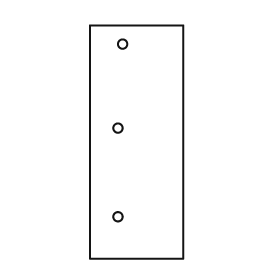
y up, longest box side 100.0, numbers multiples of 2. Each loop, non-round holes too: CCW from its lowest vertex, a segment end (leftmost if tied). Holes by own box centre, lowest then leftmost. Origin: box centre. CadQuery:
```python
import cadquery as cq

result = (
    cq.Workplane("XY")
    .moveTo(-20.0, -50.0)
    .lineTo(20.0, -50.0)
    .lineTo(20.0, 50.0)
    .lineTo(-20.0, 50.0)
    .close()
    .moveTo(-8.0, -32.0)
    .circle(2.0)
    .moveTo(-8.0, 6.0)
    .circle(2.0)
    .moveTo(-6.0, 42.0)
    .circle(2.0)
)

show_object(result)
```